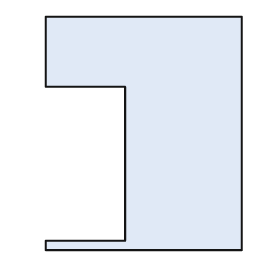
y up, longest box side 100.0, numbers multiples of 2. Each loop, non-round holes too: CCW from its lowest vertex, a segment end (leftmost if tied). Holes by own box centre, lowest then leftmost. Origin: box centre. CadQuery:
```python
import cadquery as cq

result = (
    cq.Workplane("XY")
    .moveTo(-42.0, -50.0)
    .lineTo(42.0, -50.0)
    .lineTo(42.0, 50.0)
    .lineTo(-42.0, 50.0)
    .lineTo(-42.0, 20.0)
    .lineTo(-8.0, 20.0)
    .lineTo(-8.0, -46.0)
    .lineTo(-42.0, -46.0)
    .close()
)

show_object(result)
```